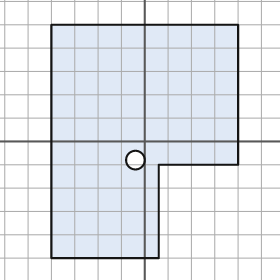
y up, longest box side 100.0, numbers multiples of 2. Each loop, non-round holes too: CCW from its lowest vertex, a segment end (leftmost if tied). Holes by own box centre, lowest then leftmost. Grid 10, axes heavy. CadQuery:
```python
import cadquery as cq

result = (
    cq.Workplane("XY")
    .moveTo(-40.0, -50.0)
    .lineTo(6.0, -50.0)
    .lineTo(6.0, -10.0)
    .lineTo(40.0, -10.0)
    .lineTo(40.0, 50.0)
    .lineTo(-40.0, 50.0)
    .close()
    .moveTo(-4.0, -8.0)
    .circle(4.0)
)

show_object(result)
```